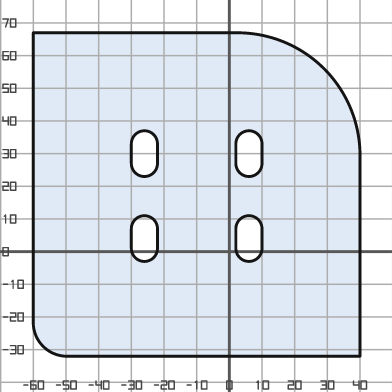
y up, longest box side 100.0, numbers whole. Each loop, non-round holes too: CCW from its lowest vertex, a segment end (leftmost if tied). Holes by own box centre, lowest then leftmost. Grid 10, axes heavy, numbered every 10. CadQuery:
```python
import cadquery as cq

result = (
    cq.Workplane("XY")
    .moveTo(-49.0, -32.0)
    .lineTo(40.0, -32.0)
    .lineTo(40.0, 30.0)
    .threePointArc((29.0, 56.0), (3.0, 67.0))
    .lineTo(-60.0, 67.0)
    .lineTo(-60.0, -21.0)
    .threePointArc((-57.0, -29.0), (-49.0, -32.0))
    .close()
    .moveTo(-30.0, 1.0)
    .threePointArc((-26.0, -3.0), (-22.0, 1.0))
    .lineTo(-22.0, 7.0)
    .threePointArc((-26.0, 11.0), (-30.0, 7.0))
    .close()
    .moveTo(2.0, 1.0)
    .threePointArc((6.0, -3.0), (10.0, 1.0))
    .lineTo(10.0, 7.0)
    .threePointArc((6.0, 11.0), (2.0, 7.0))
    .close()
    .moveTo(-30.0, 27.0)
    .threePointArc((-26.0, 23.0), (-22.0, 27.0))
    .lineTo(-22.0, 33.0)
    .threePointArc((-26.0, 37.0), (-30.0, 33.0))
    .close()
    .moveTo(2.0, 27.0)
    .threePointArc((6.0, 23.0), (10.0, 27.0))
    .lineTo(10.0, 33.0)
    .threePointArc((6.0, 37.0), (2.0, 33.0))
    .close()
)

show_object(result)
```